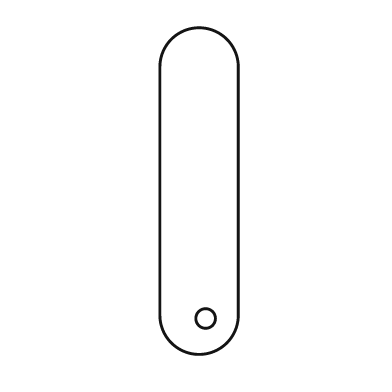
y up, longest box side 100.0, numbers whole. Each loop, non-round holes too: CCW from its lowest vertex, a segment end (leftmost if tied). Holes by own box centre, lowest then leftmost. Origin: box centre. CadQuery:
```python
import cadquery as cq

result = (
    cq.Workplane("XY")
    .moveTo(-12.0, -38.0)
    .threePointArc((0.0, -50.0), (12.0, -38.0))
    .lineTo(12.0, 38.0)
    .threePointArc((0.0, 50.0), (-12.0, 38.0))
    .close()
    .moveTo(2.0, -39.0)
    .circle(3.0)
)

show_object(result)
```